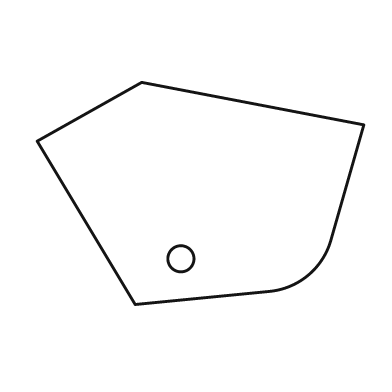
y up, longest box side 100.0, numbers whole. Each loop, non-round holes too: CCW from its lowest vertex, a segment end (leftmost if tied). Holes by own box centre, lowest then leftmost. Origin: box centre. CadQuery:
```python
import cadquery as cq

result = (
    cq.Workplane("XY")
    .moveTo(-20.0, -34.0)
    .lineTo(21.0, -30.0)
    .threePointArc((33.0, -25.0), (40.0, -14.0))
    .lineTo(50.0, 21.0)
    .lineTo(-18.0, 34.0)
    .lineTo(-50.0, 16.0)
    .close()
    .moveTo(-6.0, -20.0)
    .circle(4.0)
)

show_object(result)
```